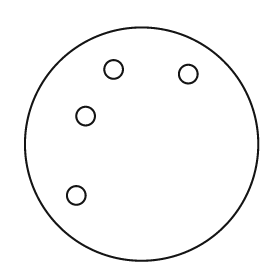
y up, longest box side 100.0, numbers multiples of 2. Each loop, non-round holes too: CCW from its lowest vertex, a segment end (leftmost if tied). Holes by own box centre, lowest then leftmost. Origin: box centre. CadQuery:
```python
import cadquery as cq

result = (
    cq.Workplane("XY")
    .moveTo(0.0, 0.0)
    .circle(50.0)
    .moveTo(-28.0, -22.0)
    .circle(4.0)
    .moveTo(-24.0, 12.0)
    .circle(4.0)
    .moveTo(20.0, 30.0)
    .circle(4.0)
    .moveTo(-12.0, 32.0)
    .circle(4.0)
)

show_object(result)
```